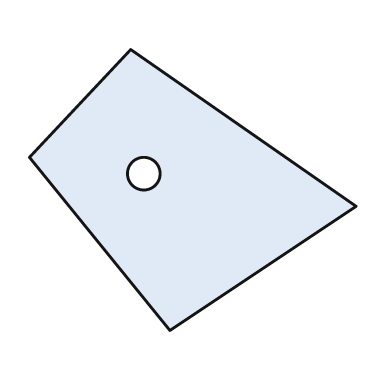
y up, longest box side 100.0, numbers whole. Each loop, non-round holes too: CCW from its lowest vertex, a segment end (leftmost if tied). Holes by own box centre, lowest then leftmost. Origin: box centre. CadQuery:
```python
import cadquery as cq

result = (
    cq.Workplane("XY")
    .moveTo(-7.0, -43.0)
    .lineTo(50.0, -5.0)
    .lineTo(-19.0, 43.0)
    .lineTo(-50.0, 10.0)
    .close()
    .moveTo(-15.0, 5.0)
    .circle(5.0)
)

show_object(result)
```